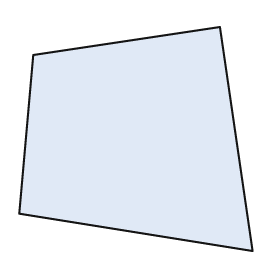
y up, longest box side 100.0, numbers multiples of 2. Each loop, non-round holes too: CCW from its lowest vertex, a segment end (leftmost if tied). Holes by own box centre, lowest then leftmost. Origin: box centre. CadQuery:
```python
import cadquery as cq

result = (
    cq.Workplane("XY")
    .moveTo(50.0, -48.0)
    .lineTo(36.0, 48.0)
    .lineTo(-44.0, 36.0)
    .lineTo(-50.0, -32.0)
    .close()
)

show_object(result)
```